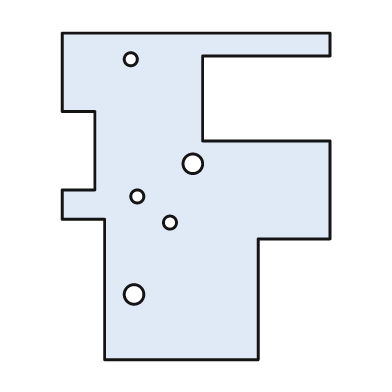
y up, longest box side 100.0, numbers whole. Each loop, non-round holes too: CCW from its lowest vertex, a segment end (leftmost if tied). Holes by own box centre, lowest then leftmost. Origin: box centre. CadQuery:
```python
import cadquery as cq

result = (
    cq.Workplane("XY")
    .moveTo(-28.0, -50.0)
    .lineTo(19.0, -50.0)
    .lineTo(19.0, -13.0)
    .lineTo(41.0, -13.0)
    .lineTo(41.0, 17.0)
    .lineTo(2.0, 17.0)
    .lineTo(2.0, 43.0)
    .lineTo(41.0, 43.0)
    .lineTo(41.0, 50.0)
    .lineTo(-41.0, 50.0)
    .lineTo(-41.0, 26.0)
    .lineTo(-31.0, 26.0)
    .lineTo(-31.0, 2.0)
    .lineTo(-41.0, 2.0)
    .lineTo(-41.0, -7.0)
    .lineTo(-28.0, -7.0)
    .close()
    .moveTo(-19.0, -30.0)
    .circle(3.0)
    .moveTo(-8.0, -8.0)
    .circle(2.0)
    .moveTo(-18.0, 0.0)
    .circle(2.0)
    .moveTo(-1.0, 10.0)
    .circle(3.0)
    .moveTo(-20.0, 42.0)
    .circle(2.0)
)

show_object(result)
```